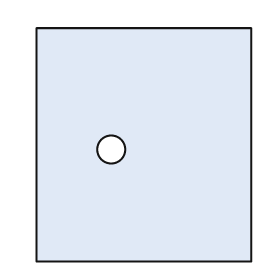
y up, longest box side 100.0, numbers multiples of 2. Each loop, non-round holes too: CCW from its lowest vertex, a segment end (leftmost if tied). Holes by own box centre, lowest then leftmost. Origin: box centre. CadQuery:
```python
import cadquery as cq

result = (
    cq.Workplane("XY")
    .moveTo(-46.0, -50.0)
    .lineTo(46.0, -50.0)
    .lineTo(46.0, 50.0)
    .lineTo(-46.0, 50.0)
    .close()
    .moveTo(-14.0, -2.0)
    .circle(6.0)
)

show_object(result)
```